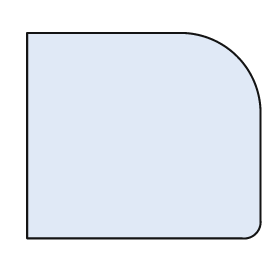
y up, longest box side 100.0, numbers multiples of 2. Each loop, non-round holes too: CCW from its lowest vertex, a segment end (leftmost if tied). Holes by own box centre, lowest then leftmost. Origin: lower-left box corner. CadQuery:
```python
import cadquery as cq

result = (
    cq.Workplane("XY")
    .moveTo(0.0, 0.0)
    .lineTo(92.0, 0.0)
    .threePointArc((98.0, 2.0), (100.0, 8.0))
    .lineTo(100.0, 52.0)
    .threePointArc((90.0, 78.0), (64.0, 88.0))
    .lineTo(0.0, 88.0)
    .close()
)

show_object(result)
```